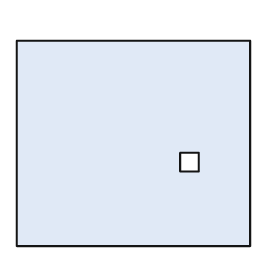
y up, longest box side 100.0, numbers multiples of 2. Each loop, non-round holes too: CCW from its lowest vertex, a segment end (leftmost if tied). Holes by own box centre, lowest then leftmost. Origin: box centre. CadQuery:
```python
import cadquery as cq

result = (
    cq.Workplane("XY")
    .moveTo(-50.0, -44.0)
    .lineTo(50.0, -44.0)
    .lineTo(50.0, 44.0)
    .lineTo(-50.0, 44.0)
    .close()
    .moveTo(20.0, -12.0)
    .lineTo(28.0, -12.0)
    .lineTo(28.0, -4.0)
    .lineTo(20.0, -4.0)
    .close()
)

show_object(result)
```